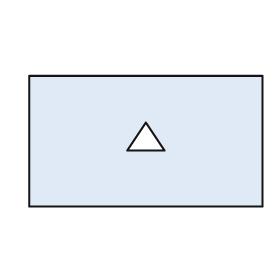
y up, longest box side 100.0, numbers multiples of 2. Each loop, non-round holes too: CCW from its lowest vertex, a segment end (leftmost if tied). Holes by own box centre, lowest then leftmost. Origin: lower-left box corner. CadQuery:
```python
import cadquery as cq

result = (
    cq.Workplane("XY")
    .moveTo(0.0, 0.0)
    .lineTo(100.0, 0.0)
    .lineTo(100.0, 56.0)
    .lineTo(0.0, 56.0)
    .close()
    .moveTo(42.0, 24.0)
    .lineTo(58.0, 24.0)
    .lineTo(50.0, 36.0)
    .close()
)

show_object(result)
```